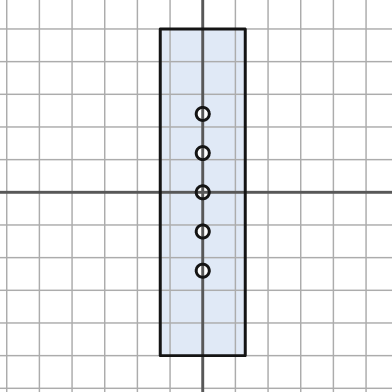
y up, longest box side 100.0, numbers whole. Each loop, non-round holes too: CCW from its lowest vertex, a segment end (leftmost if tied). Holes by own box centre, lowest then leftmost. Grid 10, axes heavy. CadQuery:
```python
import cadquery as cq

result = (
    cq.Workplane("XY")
    .moveTo(-13.0, -50.0)
    .lineTo(13.0, -50.0)
    .lineTo(13.0, 50.0)
    .lineTo(-13.0, 50.0)
    .close()
    .moveTo(0.0, -24.0)
    .circle(2.0)
    .moveTo(0.0, -12.0)
    .circle(2.0)
    .moveTo(0.0, 0.0)
    .circle(2.0)
    .moveTo(0.0, 12.0)
    .circle(2.0)
    .moveTo(0.0, 24.0)
    .circle(2.0)
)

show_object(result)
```